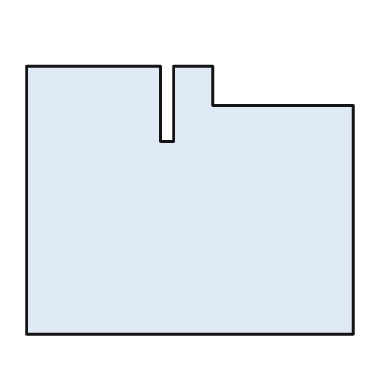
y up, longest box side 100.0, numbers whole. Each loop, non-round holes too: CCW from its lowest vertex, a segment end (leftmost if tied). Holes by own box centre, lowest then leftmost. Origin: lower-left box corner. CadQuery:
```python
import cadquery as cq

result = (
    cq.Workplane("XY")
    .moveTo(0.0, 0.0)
    .lineTo(100.0, 0.0)
    .lineTo(100.0, 70.0)
    .lineTo(57.0, 70.0)
    .lineTo(57.0, 82.0)
    .lineTo(45.0, 82.0)
    .lineTo(45.0, 59.0)
    .lineTo(41.0, 59.0)
    .lineTo(41.0, 82.0)
    .lineTo(0.0, 82.0)
    .close()
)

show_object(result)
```